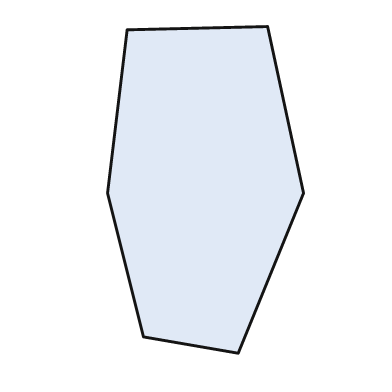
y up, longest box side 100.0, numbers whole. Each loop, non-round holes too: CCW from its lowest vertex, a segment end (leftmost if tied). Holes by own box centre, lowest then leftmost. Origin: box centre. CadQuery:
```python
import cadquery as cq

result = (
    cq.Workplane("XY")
    .moveTo(10.0, -50.0)
    .lineTo(30.0, -1.0)
    .lineTo(19.0, 50.0)
    .lineTo(-24.0, 49.0)
    .lineTo(-30.0, -1.0)
    .lineTo(-19.0, -45.0)
    .close()
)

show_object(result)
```